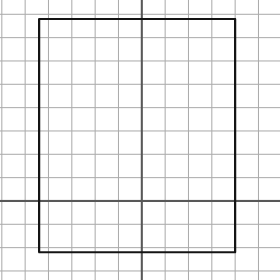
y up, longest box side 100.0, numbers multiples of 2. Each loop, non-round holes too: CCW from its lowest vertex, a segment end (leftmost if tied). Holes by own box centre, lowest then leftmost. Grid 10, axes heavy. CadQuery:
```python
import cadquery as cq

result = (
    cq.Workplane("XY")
    .moveTo(-44.0, -22.0)
    .lineTo(40.0, -22.0)
    .lineTo(40.0, 78.0)
    .lineTo(-44.0, 78.0)
    .close()
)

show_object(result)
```